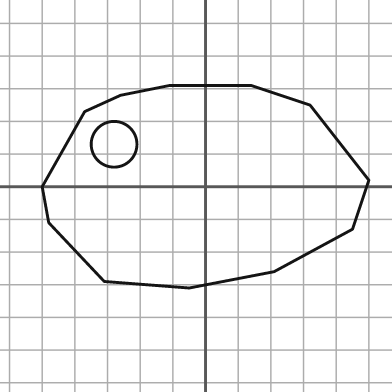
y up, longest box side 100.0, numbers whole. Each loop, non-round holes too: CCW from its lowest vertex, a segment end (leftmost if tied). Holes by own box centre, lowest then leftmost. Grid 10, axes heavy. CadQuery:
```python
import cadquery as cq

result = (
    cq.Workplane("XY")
    .moveTo(-5.0, -31.0)
    .lineTo(21.0, -26.0)
    .lineTo(45.0, -13.0)
    .lineTo(50.0, 2.0)
    .lineTo(32.0, 25.0)
    .lineTo(14.0, 31.0)
    .lineTo(-11.0, 31.0)
    .lineTo(-26.0, 28.0)
    .lineTo(-37.0, 23.0)
    .lineTo(-50.0, 0.0)
    .lineTo(-48.0, -11.0)
    .lineTo(-31.0, -29.0)
    .close()
    .moveTo(-28.0, 13.0)
    .circle(7.0)
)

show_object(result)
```